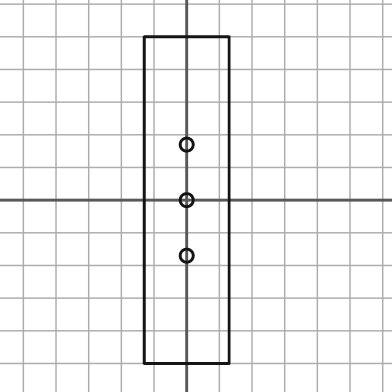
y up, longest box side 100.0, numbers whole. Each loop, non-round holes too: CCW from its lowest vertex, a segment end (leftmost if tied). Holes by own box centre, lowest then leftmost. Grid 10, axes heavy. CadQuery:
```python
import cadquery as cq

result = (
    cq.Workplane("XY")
    .moveTo(-13.0, -50.0)
    .lineTo(13.0, -50.0)
    .lineTo(13.0, 50.0)
    .lineTo(-13.0, 50.0)
    .close()
    .moveTo(0.0, -17.0)
    .circle(2.0)
    .moveTo(0.0, 0.0)
    .circle(2.0)
    .moveTo(0.0, 17.0)
    .circle(2.0)
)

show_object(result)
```